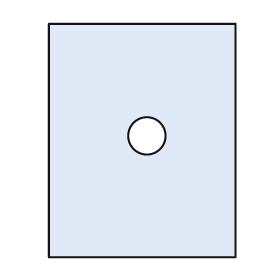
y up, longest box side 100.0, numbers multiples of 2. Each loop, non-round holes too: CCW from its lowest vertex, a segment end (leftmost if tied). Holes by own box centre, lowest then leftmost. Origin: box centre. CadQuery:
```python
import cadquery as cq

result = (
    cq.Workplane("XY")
    .moveTo(-40.0, -50.0)
    .lineTo(40.0, -50.0)
    .lineTo(40.0, 50.0)
    .lineTo(-40.0, 50.0)
    .close()
    .moveTo(2.0, 2.0)
    .circle(8.0)
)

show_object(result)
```